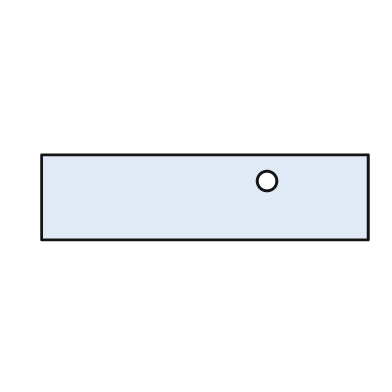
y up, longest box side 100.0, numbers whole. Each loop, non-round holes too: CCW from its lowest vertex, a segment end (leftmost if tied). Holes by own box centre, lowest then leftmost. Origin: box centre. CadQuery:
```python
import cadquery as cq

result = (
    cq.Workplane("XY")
    .moveTo(-50.0, -13.0)
    .lineTo(50.0, -13.0)
    .lineTo(50.0, 13.0)
    .lineTo(-50.0, 13.0)
    .close()
    .moveTo(19.0, 5.0)
    .circle(3.0)
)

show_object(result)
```